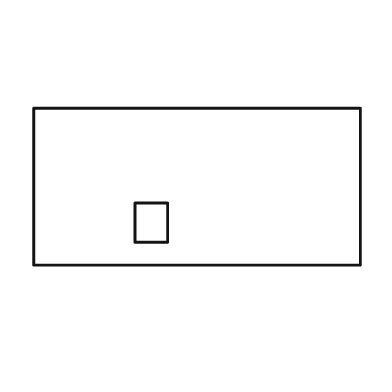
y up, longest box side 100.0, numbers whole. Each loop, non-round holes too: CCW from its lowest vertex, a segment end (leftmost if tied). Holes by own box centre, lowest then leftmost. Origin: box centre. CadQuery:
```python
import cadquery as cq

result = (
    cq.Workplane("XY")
    .moveTo(-50.0, -24.0)
    .lineTo(50.0, -24.0)
    .lineTo(50.0, 24.0)
    .lineTo(-50.0, 24.0)
    .close()
    .moveTo(-19.0, -17.0)
    .lineTo(-9.0, -17.0)
    .lineTo(-9.0, -5.0)
    .lineTo(-19.0, -5.0)
    .close()
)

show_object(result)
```